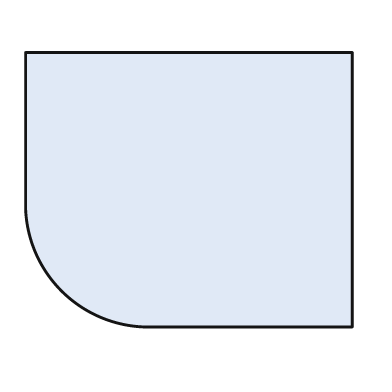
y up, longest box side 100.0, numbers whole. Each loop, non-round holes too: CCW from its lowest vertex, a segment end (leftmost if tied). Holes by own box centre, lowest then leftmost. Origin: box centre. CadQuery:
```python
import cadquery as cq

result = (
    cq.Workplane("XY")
    .moveTo(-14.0, -42.0)
    .lineTo(50.0, -42.0)
    .lineTo(50.0, 42.0)
    .lineTo(-50.0, 42.0)
    .lineTo(-50.0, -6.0)
    .threePointArc((-39.0, -31.0), (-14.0, -42.0))
    .close()
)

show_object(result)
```